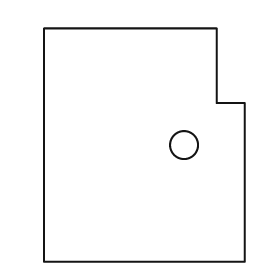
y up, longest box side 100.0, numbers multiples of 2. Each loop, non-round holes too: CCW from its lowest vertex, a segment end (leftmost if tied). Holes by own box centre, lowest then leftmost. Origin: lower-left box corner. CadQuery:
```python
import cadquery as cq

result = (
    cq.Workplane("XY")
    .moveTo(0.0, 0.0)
    .lineTo(86.0, 0.0)
    .lineTo(86.0, 68.0)
    .lineTo(74.0, 68.0)
    .lineTo(74.0, 100.0)
    .lineTo(0.0, 100.0)
    .close()
    .moveTo(60.0, 50.0)
    .circle(6.0)
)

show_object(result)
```